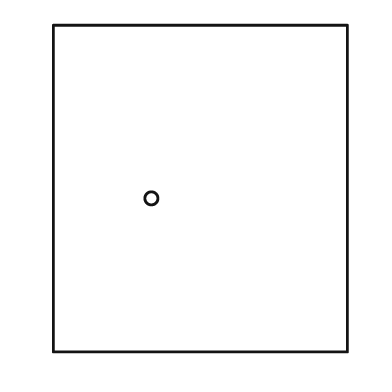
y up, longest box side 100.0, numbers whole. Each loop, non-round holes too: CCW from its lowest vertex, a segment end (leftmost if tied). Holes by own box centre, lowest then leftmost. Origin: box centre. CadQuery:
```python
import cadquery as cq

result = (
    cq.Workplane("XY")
    .moveTo(-45.0, -50.0)
    .lineTo(45.0, -50.0)
    .lineTo(45.0, 50.0)
    .lineTo(-45.0, 50.0)
    .close()
    .moveTo(-15.0, -3.0)
    .circle(2.0)
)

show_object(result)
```